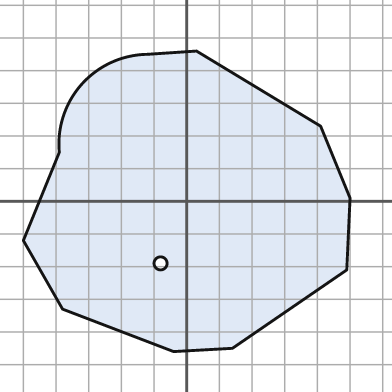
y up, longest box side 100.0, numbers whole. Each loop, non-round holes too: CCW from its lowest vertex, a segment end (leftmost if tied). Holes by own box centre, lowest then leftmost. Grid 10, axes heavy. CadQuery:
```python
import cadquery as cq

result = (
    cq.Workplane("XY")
    .moveTo(-4.0, -46.0)
    .lineTo(14.0, -45.0)
    .lineTo(49.0, -21.0)
    .lineTo(50.0, 1.0)
    .lineTo(41.0, 23.0)
    .lineTo(3.0, 46.0)
    .lineTo(-12.0, 45.0)
    .threePointArc((-32.0, 36.0), (-39.0, 15.0))
    .lineTo(-50.0, -12.0)
    .lineTo(-38.0, -33.0)
    .close()
    .moveTo(-8.0, -19.0)
    .circle(2.0)
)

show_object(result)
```